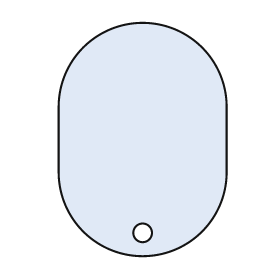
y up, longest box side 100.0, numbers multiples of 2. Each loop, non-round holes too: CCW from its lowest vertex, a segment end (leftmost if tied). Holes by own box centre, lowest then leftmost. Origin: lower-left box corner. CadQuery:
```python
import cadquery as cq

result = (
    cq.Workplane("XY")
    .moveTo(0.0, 36.0)
    .threePointArc((36.0, 0.0), (72.0, 36.0))
    .lineTo(72.0, 64.0)
    .threePointArc((36.0, 100.0), (0.0, 64.0))
    .close()
    .moveTo(36.0, 10.0)
    .circle(4.0)
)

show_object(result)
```